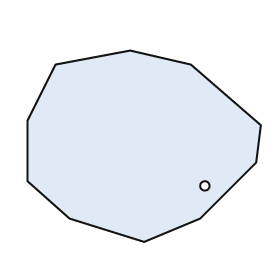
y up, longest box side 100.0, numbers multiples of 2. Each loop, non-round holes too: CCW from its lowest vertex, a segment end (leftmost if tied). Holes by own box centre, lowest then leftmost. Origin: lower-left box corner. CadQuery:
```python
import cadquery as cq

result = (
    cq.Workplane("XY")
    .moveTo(50.0, 0.0)
    .lineTo(74.0, 10.0)
    .lineTo(98.0, 34.0)
    .lineTo(100.0, 50.0)
    .lineTo(70.0, 76.0)
    .lineTo(44.0, 82.0)
    .lineTo(12.0, 76.0)
    .lineTo(0.0, 52.0)
    .lineTo(0.0, 26.0)
    .lineTo(18.0, 10.0)
    .close()
    .moveTo(76.0, 24.0)
    .circle(2.0)
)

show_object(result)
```